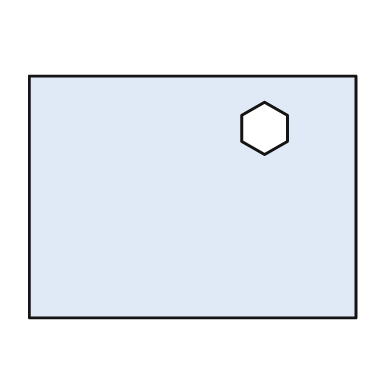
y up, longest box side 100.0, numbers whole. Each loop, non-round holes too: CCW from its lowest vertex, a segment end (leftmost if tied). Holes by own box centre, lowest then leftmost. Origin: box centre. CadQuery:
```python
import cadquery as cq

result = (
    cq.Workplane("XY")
    .moveTo(-50.0, -37.0)
    .lineTo(50.0, -37.0)
    .lineTo(50.0, 37.0)
    .lineTo(-50.0, 37.0)
    .close()
    .moveTo(22.0, 13.0)
    .lineTo(29.0, 17.0)
    .lineTo(29.0, 25.0)
    .lineTo(22.0, 29.0)
    .lineTo(15.0, 25.0)
    .lineTo(15.0, 17.0)
    .close()
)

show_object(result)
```